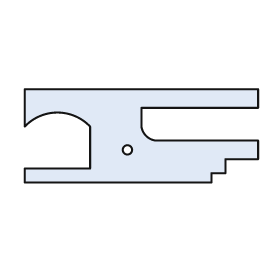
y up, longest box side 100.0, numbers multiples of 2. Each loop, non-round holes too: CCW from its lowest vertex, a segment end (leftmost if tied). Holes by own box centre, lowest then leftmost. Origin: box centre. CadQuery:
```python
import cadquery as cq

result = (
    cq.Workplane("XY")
    .moveTo(-50.0, -20.0)
    .lineTo(30.0, -20.0)
    .lineTo(30.0, -16.0)
    .lineTo(36.0, -16.0)
    .lineTo(36.0, -10.0)
    .lineTo(50.0, -10.0)
    .lineTo(50.0, -2.0)
    .lineTo(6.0, -2.0)
    .threePointArc((2.0, 0.0), (0.0, 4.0))
    .lineTo(0.0, 12.0)
    .lineTo(50.0, 12.0)
    .lineTo(50.0, 20.0)
    .lineTo(-50.0, 20.0)
    .lineTo(-50.0, 4.0)
    .threePointArc((-36.0, 10.0), (-22.0, 4.0))
    .lineTo(-22.0, -14.0)
    .lineTo(-50.0, -14.0)
    .close()
    .moveTo(-6.0, -6.0)
    .circle(2.0)
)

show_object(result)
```